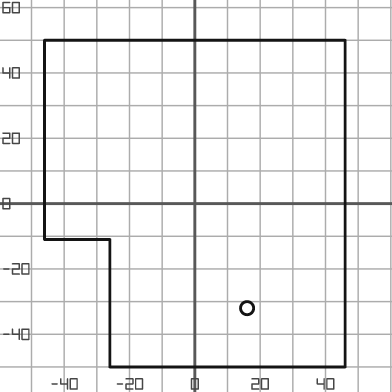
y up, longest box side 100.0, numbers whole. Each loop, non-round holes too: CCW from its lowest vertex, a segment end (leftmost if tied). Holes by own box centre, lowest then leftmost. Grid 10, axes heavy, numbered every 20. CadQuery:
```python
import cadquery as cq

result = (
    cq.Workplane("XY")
    .moveTo(-26.0, -50.0)
    .lineTo(46.0, -50.0)
    .lineTo(46.0, 50.0)
    .lineTo(-46.0, 50.0)
    .lineTo(-46.0, -11.0)
    .lineTo(-26.0, -11.0)
    .close()
    .moveTo(16.0, -32.0)
    .circle(2.0)
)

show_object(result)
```